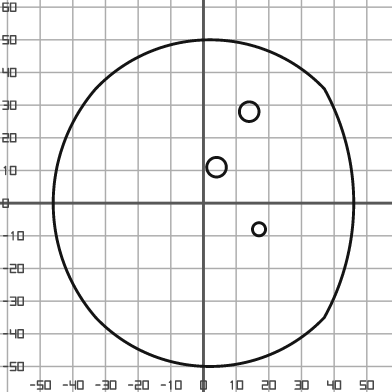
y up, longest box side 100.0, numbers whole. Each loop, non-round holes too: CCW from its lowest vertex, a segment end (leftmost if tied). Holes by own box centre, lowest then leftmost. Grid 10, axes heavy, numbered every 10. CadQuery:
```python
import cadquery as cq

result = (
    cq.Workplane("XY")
    .moveTo(-33.0, -35.0)
    .threePointArc((2.0, -50.0), (37.0, -35.0))
    .threePointArc((46.0, 0.0), (37.0, 35.0))
    .threePointArc((2.0, 50.0), (-33.0, 35.0))
    .threePointArc((-46.0, 0.0), (-33.0, -35.0))
    .close()
    .moveTo(17.0, -8.0)
    .circle(2.0)
    .moveTo(4.0, 11.0)
    .circle(3.0)
    .moveTo(14.0, 28.0)
    .circle(3.0)
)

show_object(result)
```